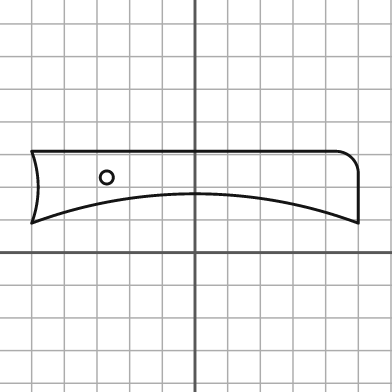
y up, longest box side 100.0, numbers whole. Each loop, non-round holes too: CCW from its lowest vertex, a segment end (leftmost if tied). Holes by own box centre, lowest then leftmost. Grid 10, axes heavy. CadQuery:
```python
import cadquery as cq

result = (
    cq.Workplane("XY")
    .moveTo(-50.0, 9.0)
    .threePointArc((0.0, 18.0), (50.0, 9.0))
    .lineTo(50.0, 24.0)
    .threePointArc((48.0, 29.0), (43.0, 31.0))
    .lineTo(-50.0, 31.0)
    .threePointArc((-48.0, 20.0), (-50.0, 9.0))
    .close()
    .moveTo(-27.0, 23.0)
    .circle(2.0)
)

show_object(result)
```